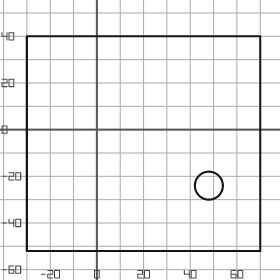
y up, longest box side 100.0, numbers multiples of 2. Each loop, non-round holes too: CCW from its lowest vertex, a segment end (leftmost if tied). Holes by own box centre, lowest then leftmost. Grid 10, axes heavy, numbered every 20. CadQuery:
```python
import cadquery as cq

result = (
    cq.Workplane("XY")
    .moveTo(-30.0, -52.0)
    .lineTo(70.0, -52.0)
    .lineTo(70.0, 40.0)
    .lineTo(-30.0, 40.0)
    .close()
    .moveTo(48.0, -24.0)
    .circle(6.0)
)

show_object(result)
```